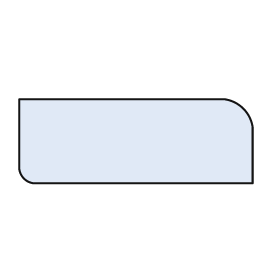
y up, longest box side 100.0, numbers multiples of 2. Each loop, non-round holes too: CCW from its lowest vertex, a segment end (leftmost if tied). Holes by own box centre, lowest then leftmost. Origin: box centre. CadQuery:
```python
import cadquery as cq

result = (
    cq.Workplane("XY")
    .moveTo(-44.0, -18.0)
    .lineTo(50.0, -18.0)
    .lineTo(50.0, 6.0)
    .threePointArc((46.0, 14.0), (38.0, 18.0))
    .lineTo(-50.0, 18.0)
    .lineTo(-50.0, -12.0)
    .threePointArc((-48.0, -16.0), (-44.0, -18.0))
    .close()
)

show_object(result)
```